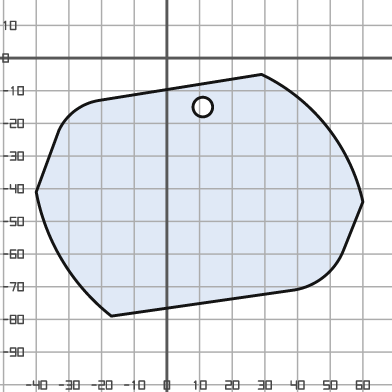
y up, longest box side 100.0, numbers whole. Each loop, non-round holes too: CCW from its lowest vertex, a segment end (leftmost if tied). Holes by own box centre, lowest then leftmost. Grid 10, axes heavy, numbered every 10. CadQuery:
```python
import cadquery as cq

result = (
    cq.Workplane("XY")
    .moveTo(-17.0, -79.0)
    .lineTo(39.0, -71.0)
    .threePointArc((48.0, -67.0), (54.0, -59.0))
    .lineTo(60.0, -44.0)
    .threePointArc((49.0, -21.0), (29.0, -5.0))
    .lineTo(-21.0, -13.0)
    .threePointArc((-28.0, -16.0), (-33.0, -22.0))
    .lineTo(-40.0, -41.0)
    .threePointArc((-32.0, -62.0), (-17.0, -79.0))
    .close()
    .moveTo(11.0, -15.0)
    .circle(3.0)
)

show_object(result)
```